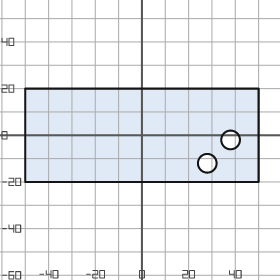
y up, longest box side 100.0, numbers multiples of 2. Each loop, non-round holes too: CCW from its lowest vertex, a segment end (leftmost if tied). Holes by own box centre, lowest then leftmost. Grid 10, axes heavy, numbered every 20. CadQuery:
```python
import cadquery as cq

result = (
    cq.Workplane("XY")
    .moveTo(-50.0, -20.0)
    .lineTo(50.0, -20.0)
    .lineTo(50.0, 20.0)
    .lineTo(-50.0, 20.0)
    .close()
    .moveTo(28.0, -12.0)
    .circle(4.0)
    .moveTo(38.0, -2.0)
    .circle(4.0)
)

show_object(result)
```